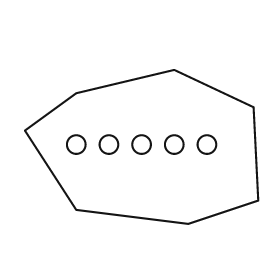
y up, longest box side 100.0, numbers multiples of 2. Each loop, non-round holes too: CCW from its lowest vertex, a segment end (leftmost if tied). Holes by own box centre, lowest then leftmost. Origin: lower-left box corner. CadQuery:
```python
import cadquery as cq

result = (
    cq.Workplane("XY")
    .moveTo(70.0, 0.0)
    .lineTo(100.0, 10.0)
    .lineTo(98.0, 50.0)
    .lineTo(64.0, 66.0)
    .lineTo(22.0, 56.0)
    .lineTo(0.0, 40.0)
    .lineTo(22.0, 6.0)
    .close()
    .moveTo(22.0, 34.0)
    .circle(4.0)
    .moveTo(36.0, 34.0)
    .circle(4.0)
    .moveTo(50.0, 34.0)
    .circle(4.0)
    .moveTo(64.0, 34.0)
    .circle(4.0)
    .moveTo(78.0, 34.0)
    .circle(4.0)
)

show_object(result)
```